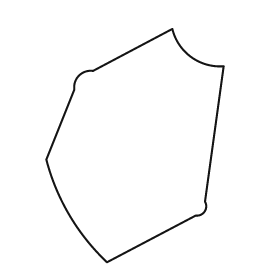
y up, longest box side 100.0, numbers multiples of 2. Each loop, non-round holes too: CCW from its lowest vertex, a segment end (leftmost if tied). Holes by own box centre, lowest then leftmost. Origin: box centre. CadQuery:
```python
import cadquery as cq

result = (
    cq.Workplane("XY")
    .moveTo(-12.0, -50.0)
    .lineTo(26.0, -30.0)
    .threePointArc((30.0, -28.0), (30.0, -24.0))
    .lineTo(38.0, 34.0)
    .threePointArc((24.0, 38.0), (16.0, 50.0))
    .lineTo(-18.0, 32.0)
    .threePointArc((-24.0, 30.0), (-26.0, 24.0))
    .lineTo(-38.0, -6.0)
    .threePointArc((-28.0, -30.0), (-12.0, -50.0))
    .close()
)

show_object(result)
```